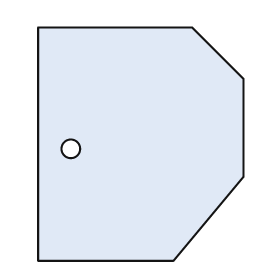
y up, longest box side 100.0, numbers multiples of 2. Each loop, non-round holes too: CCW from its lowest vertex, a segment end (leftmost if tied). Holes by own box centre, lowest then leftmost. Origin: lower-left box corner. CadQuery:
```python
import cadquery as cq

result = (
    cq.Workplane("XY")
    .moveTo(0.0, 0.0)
    .lineTo(58.0, 0.0)
    .lineTo(88.0, 36.0)
    .lineTo(88.0, 78.0)
    .lineTo(66.0, 100.0)
    .lineTo(0.0, 100.0)
    .close()
    .moveTo(14.0, 48.0)
    .circle(4.0)
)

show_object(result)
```